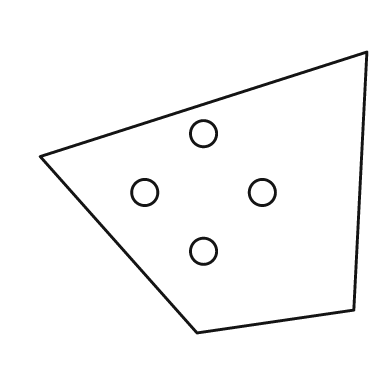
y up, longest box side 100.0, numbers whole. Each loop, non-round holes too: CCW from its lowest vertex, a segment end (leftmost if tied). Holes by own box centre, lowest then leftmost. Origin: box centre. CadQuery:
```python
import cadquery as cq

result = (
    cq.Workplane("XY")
    .moveTo(-2.0, -43.0)
    .lineTo(46.0, -36.0)
    .lineTo(50.0, 43.0)
    .lineTo(-50.0, 11.0)
    .close()
    .moveTo(0.0, -18.0)
    .circle(4.0)
    .moveTo(-18.0, 0.0)
    .circle(4.0)
    .moveTo(18.0, 0.0)
    .circle(4.0)
    .moveTo(0.0, 18.0)
    .circle(4.0)
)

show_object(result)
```